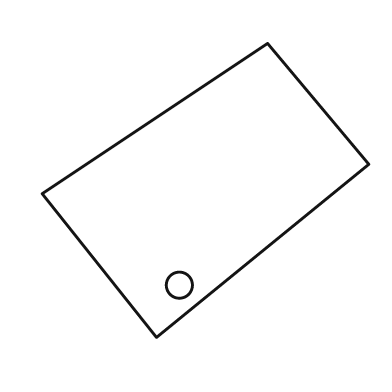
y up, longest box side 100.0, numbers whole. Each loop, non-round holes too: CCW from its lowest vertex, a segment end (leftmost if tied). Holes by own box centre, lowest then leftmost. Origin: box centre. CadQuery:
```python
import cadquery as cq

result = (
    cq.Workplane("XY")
    .moveTo(-15.0, -45.0)
    .lineTo(50.0, 8.0)
    .lineTo(19.0, 45.0)
    .lineTo(-50.0, -1.0)
    .close()
    .moveTo(-8.0, -29.0)
    .circle(4.0)
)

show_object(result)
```